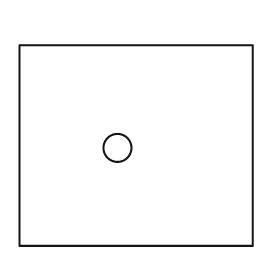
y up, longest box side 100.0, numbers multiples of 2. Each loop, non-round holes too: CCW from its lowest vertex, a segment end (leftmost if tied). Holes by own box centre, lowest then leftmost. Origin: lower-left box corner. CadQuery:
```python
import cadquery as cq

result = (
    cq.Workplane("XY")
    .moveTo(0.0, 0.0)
    .lineTo(100.0, 0.0)
    .lineTo(100.0, 86.0)
    .lineTo(0.0, 86.0)
    .close()
    .moveTo(42.0, 42.0)
    .circle(6.0)
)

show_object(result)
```